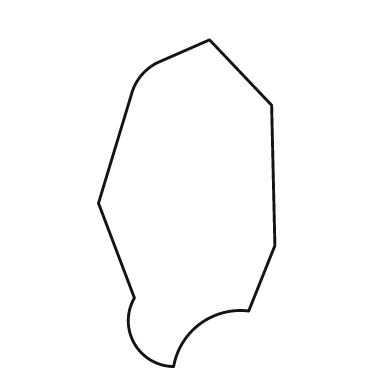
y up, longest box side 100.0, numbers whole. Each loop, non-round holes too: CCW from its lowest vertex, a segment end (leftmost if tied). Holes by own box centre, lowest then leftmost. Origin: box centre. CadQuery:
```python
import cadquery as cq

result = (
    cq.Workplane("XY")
    .moveTo(-4.0, -50.0)
    .threePointArc((4.0, -37.0), (19.0, -33.0))
    .lineTo(27.0, -13.0)
    .lineTo(26.0, 30.0)
    .lineTo(7.0, 50.0)
    .lineTo(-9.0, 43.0)
    .threePointArc((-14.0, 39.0), (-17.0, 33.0))
    .lineTo(-27.0, 0.0)
    .lineTo(-16.0, -29.0)
    .threePointArc((-16.0, -43.0), (-4.0, -50.0))
    .close()
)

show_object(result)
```